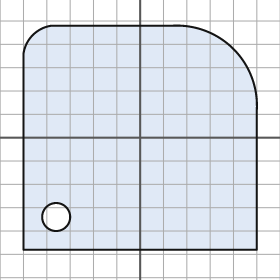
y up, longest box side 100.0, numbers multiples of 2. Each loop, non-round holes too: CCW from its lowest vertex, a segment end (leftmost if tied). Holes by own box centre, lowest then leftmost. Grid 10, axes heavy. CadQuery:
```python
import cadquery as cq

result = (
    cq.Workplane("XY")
    .moveTo(-50.0, -48.0)
    .lineTo(50.0, -48.0)
    .lineTo(50.0, 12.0)
    .threePointArc((40.0, 38.0), (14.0, 48.0))
    .lineTo(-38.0, 48.0)
    .threePointArc((-46.0, 44.0), (-50.0, 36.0))
    .close()
    .moveTo(-36.0, -34.0)
    .circle(6.0)
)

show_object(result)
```